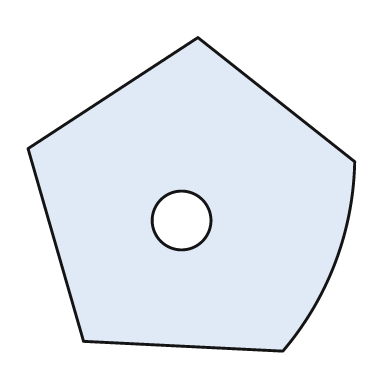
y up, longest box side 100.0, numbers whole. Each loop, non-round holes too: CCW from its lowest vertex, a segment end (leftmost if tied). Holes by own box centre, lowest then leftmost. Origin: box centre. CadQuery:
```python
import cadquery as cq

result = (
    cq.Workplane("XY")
    .moveTo(28.0, -48.0)
    .threePointArc((44.0, -21.0), (50.0, 10.0))
    .lineTo(2.0, 48.0)
    .lineTo(-50.0, 14.0)
    .lineTo(-33.0, -45.0)
    .close()
    .moveTo(-3.0, -8.0)
    .circle(9.0)
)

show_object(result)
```